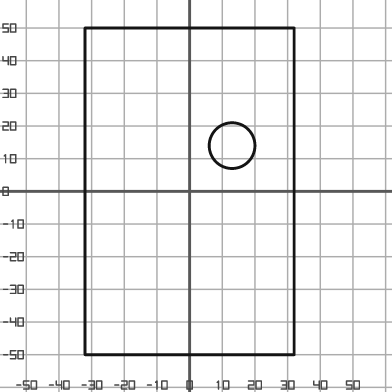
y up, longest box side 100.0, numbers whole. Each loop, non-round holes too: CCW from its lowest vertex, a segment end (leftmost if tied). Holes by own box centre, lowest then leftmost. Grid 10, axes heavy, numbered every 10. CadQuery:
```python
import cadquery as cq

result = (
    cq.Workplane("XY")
    .moveTo(-32.0, -50.0)
    .lineTo(32.0, -50.0)
    .lineTo(32.0, 50.0)
    .lineTo(-32.0, 50.0)
    .close()
    .moveTo(13.0, 14.0)
    .circle(7.0)
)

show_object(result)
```